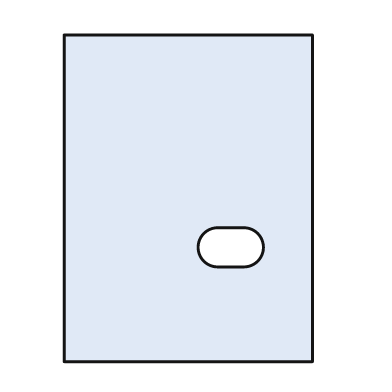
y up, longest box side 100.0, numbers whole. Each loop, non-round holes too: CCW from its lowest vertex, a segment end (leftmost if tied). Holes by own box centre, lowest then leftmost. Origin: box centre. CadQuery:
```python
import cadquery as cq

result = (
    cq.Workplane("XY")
    .moveTo(-38.0, -50.0)
    .lineTo(38.0, -50.0)
    .lineTo(38.0, 50.0)
    .lineTo(-38.0, 50.0)
    .close()
    .moveTo(9.0, -21.0)
    .lineTo(17.0, -21.0)
    .threePointArc((23.0, -15.0), (17.0, -9.0))
    .lineTo(9.0, -9.0)
    .threePointArc((3.0, -15.0), (9.0, -21.0))
    .close()
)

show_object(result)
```